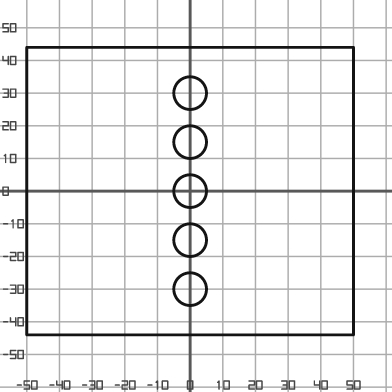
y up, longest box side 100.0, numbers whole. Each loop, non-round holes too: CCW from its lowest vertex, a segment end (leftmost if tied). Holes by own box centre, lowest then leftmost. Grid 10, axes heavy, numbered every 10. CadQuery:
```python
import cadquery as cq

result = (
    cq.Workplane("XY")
    .moveTo(-50.0, -44.0)
    .lineTo(50.0, -44.0)
    .lineTo(50.0, 44.0)
    .lineTo(-50.0, 44.0)
    .close()
    .moveTo(0.0, -30.0)
    .circle(5.0)
    .moveTo(0.0, -15.0)
    .circle(5.0)
    .moveTo(0.0, 0.0)
    .circle(5.0)
    .moveTo(0.0, 15.0)
    .circle(5.0)
    .moveTo(0.0, 30.0)
    .circle(5.0)
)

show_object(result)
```